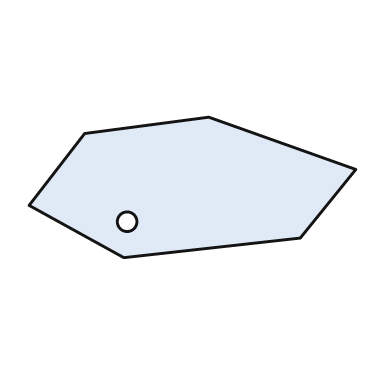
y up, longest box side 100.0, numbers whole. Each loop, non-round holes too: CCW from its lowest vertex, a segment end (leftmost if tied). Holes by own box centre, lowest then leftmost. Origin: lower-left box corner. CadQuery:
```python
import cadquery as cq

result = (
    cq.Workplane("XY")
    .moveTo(29.0, 0.0)
    .lineTo(83.0, 6.0)
    .lineTo(100.0, 27.0)
    .lineTo(55.0, 43.0)
    .lineTo(17.0, 38.0)
    .lineTo(0.0, 16.0)
    .close()
    .moveTo(30.0, 11.0)
    .circle(3.0)
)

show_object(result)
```